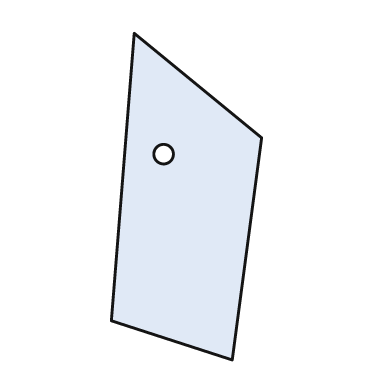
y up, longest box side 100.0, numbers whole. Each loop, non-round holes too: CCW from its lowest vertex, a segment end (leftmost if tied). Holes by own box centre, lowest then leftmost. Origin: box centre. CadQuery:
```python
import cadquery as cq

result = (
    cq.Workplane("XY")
    .moveTo(14.0, -50.0)
    .lineTo(23.0, 18.0)
    .lineTo(-16.0, 50.0)
    .lineTo(-23.0, -38.0)
    .close()
    .moveTo(-7.0, 13.0)
    .circle(3.0)
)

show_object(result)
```